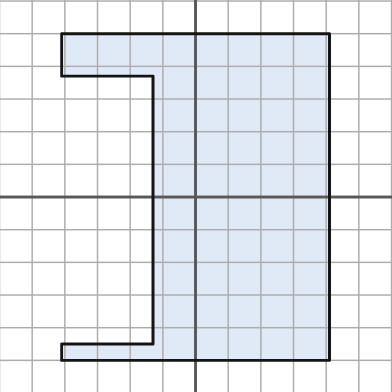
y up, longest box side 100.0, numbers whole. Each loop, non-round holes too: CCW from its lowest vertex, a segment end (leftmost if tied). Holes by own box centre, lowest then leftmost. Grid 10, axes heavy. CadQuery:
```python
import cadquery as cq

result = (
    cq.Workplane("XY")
    .moveTo(-41.0, -50.0)
    .lineTo(41.0, -50.0)
    .lineTo(41.0, 50.0)
    .lineTo(-41.0, 50.0)
    .lineTo(-41.0, 37.0)
    .lineTo(-13.0, 37.0)
    .lineTo(-13.0, -45.0)
    .lineTo(-41.0, -45.0)
    .close()
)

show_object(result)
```